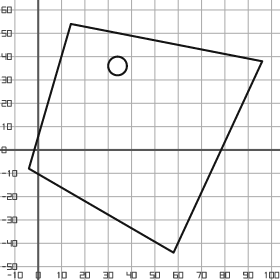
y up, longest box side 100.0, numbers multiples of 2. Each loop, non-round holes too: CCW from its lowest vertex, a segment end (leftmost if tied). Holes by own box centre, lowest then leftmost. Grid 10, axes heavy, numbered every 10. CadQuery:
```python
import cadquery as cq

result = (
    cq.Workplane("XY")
    .moveTo(58.0, -44.0)
    .lineTo(96.0, 38.0)
    .lineTo(14.0, 54.0)
    .lineTo(-4.0, -8.0)
    .close()
    .moveTo(34.0, 36.0)
    .circle(4.0)
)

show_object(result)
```